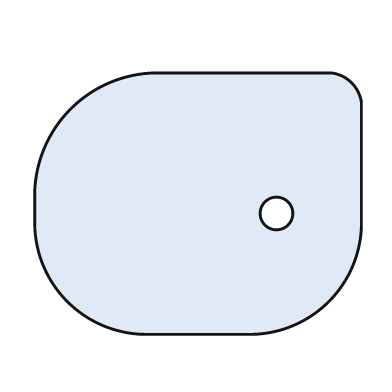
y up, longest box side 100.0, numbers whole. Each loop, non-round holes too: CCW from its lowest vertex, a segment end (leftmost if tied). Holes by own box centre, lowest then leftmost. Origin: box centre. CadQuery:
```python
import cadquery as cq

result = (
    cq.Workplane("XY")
    .moveTo(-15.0, -40.0)
    .lineTo(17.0, -40.0)
    .threePointArc((40.0, -30.0), (50.0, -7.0))
    .lineTo(50.0, 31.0)
    .threePointArc((47.0, 37.0), (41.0, 40.0))
    .lineTo(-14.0, 40.0)
    .threePointArc((-39.0, 29.0), (-50.0, 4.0))
    .lineTo(-50.0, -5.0)
    .threePointArc((-40.0, -30.0), (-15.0, -40.0))
    .close()
    .moveTo(24.0, -3.0)
    .circle(5.0)
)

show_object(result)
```